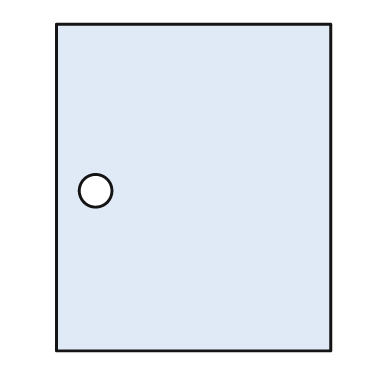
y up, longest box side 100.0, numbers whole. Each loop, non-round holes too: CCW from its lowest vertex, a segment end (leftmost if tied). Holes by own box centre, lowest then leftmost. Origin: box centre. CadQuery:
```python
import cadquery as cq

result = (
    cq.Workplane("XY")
    .moveTo(-42.0, -50.0)
    .lineTo(42.0, -50.0)
    .lineTo(42.0, 50.0)
    .lineTo(-42.0, 50.0)
    .close()
    .moveTo(-30.0, -1.0)
    .circle(5.0)
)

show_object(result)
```